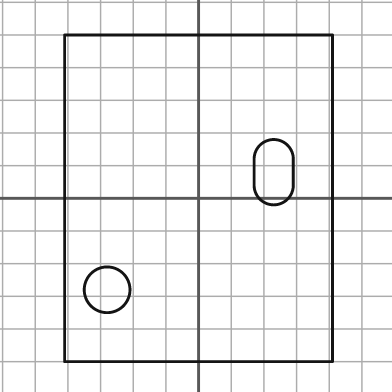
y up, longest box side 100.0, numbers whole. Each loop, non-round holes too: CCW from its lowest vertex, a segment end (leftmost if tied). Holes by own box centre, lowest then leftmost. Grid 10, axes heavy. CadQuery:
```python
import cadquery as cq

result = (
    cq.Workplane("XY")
    .moveTo(-41.0, -50.0)
    .lineTo(41.0, -50.0)
    .lineTo(41.0, 50.0)
    .lineTo(-41.0, 50.0)
    .close()
    .moveTo(-28.0, -28.0)
    .circle(7.0)
    .moveTo(17.0, 4.0)
    .threePointArc((23.0, -2.0), (29.0, 4.0))
    .lineTo(29.0, 12.0)
    .threePointArc((23.0, 18.0), (17.0, 12.0))
    .close()
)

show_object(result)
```